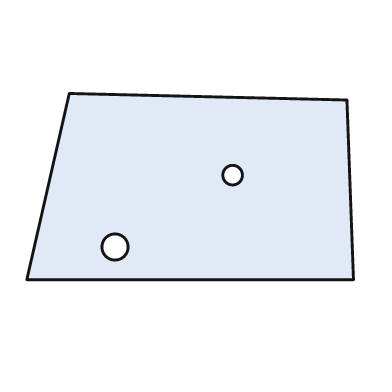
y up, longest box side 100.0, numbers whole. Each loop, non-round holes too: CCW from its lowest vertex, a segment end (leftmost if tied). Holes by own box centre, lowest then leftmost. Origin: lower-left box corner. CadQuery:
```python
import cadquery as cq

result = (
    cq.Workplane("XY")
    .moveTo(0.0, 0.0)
    .lineTo(100.0, 0.0)
    .lineTo(98.0, 55.0)
    .lineTo(13.0, 57.0)
    .close()
    .moveTo(27.0, 10.0)
    .circle(4.0)
    .moveTo(63.0, 32.0)
    .circle(3.0)
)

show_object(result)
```